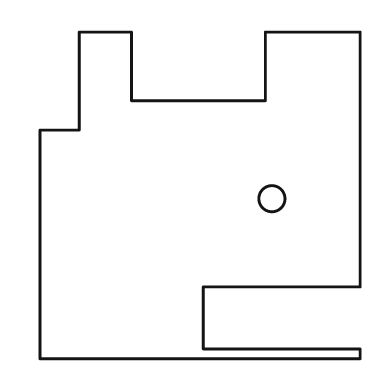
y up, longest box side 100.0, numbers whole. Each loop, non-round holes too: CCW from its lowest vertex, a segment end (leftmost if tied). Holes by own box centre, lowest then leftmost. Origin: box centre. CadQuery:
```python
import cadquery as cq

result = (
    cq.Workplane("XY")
    .moveTo(-49.0, -50.0)
    .lineTo(49.0, -50.0)
    .lineTo(49.0, -47.0)
    .lineTo(1.0, -47.0)
    .lineTo(1.0, -28.0)
    .lineTo(49.0, -28.0)
    .lineTo(49.0, 50.0)
    .lineTo(20.0, 50.0)
    .lineTo(20.0, 29.0)
    .lineTo(-21.0, 29.0)
    .lineTo(-21.0, 50.0)
    .lineTo(-37.0, 50.0)
    .lineTo(-37.0, 20.0)
    .lineTo(-49.0, 20.0)
    .close()
    .moveTo(22.0, -1.0)
    .circle(4.0)
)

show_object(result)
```